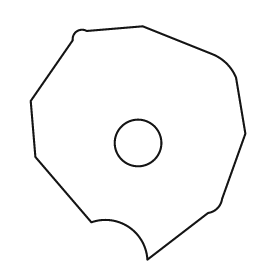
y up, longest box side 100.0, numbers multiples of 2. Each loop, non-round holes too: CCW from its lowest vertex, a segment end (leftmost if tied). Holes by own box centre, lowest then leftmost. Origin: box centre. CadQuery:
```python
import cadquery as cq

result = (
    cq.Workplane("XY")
    .moveTo(4.0, -50.0)
    .lineTo(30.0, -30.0)
    .threePointArc((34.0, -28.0), (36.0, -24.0))
    .lineTo(46.0, 4.0)
    .lineTo(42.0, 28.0)
    .threePointArc((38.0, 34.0), (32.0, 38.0))
    .lineTo(2.0, 50.0)
    .lineTo(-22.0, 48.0)
    .threePointArc((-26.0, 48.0), (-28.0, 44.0))
    .lineTo(-46.0, 18.0)
    .lineTo(-44.0, -6.0)
    .lineTo(-20.0, -34.0)
    .threePointArc((-4.0, -36.0), (4.0, -50.0))
    .close()
    .moveTo(0.0, 0.0)
    .circle(10.0)
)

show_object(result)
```